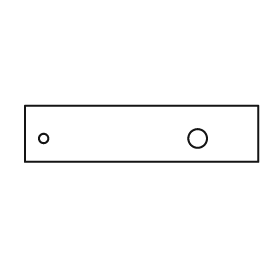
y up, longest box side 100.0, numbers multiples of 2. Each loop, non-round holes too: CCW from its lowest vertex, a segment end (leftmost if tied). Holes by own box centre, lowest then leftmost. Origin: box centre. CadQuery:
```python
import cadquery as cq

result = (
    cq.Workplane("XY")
    .moveTo(-50.0, -12.0)
    .lineTo(50.0, -12.0)
    .lineTo(50.0, 12.0)
    .lineTo(-50.0, 12.0)
    .close()
    .moveTo(-42.0, -2.0)
    .circle(2.0)
    .moveTo(24.0, -2.0)
    .circle(4.0)
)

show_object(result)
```